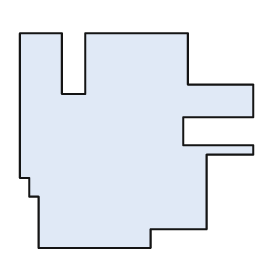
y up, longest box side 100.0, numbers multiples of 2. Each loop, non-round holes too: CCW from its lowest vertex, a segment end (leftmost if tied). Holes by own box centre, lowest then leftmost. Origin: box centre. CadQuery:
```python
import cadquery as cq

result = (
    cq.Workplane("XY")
    .moveTo(-42.0, -46.0)
    .lineTo(6.0, -46.0)
    .lineTo(6.0, -38.0)
    .lineTo(30.0, -38.0)
    .lineTo(30.0, -6.0)
    .lineTo(50.0, -6.0)
    .lineTo(50.0, -2.0)
    .lineTo(20.0, -2.0)
    .lineTo(20.0, 10.0)
    .lineTo(50.0, 10.0)
    .lineTo(50.0, 24.0)
    .lineTo(22.0, 24.0)
    .lineTo(22.0, 46.0)
    .lineTo(-22.0, 46.0)
    .lineTo(-22.0, 20.0)
    .lineTo(-32.0, 20.0)
    .lineTo(-32.0, 46.0)
    .lineTo(-50.0, 46.0)
    .lineTo(-50.0, -16.0)
    .lineTo(-46.0, -16.0)
    .lineTo(-46.0, -24.0)
    .lineTo(-42.0, -24.0)
    .close()
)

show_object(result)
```